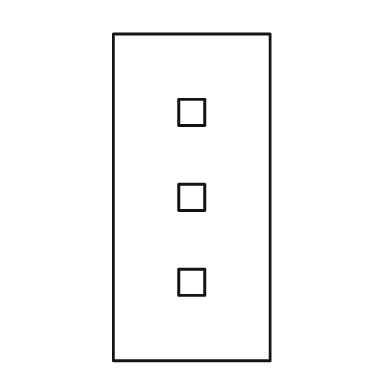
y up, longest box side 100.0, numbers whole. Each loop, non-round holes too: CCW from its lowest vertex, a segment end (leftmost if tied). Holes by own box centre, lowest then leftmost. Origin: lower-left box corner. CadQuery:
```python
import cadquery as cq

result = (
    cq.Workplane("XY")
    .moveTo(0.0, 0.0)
    .lineTo(48.0, 0.0)
    .lineTo(48.0, 100.0)
    .lineTo(0.0, 100.0)
    .close()
    .moveTo(20.0, 20.0)
    .lineTo(28.0, 20.0)
    .lineTo(28.0, 28.0)
    .lineTo(20.0, 28.0)
    .close()
    .moveTo(20.0, 46.0)
    .lineTo(28.0, 46.0)
    .lineTo(28.0, 54.0)
    .lineTo(20.0, 54.0)
    .close()
    .moveTo(20.0, 72.0)
    .lineTo(28.0, 72.0)
    .lineTo(28.0, 80.0)
    .lineTo(20.0, 80.0)
    .close()
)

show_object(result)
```